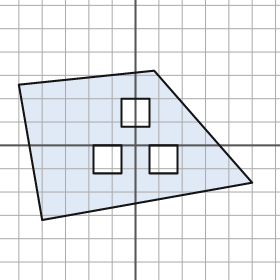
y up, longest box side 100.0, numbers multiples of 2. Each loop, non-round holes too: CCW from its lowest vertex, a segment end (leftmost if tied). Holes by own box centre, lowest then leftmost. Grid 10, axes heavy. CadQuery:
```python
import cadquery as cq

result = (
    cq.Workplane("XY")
    .moveTo(-40.0, -32.0)
    .lineTo(50.0, -16.0)
    .lineTo(8.0, 32.0)
    .lineTo(-50.0, 26.0)
    .close()
    .moveTo(-18.0, -12.0)
    .lineTo(-6.0, -12.0)
    .lineTo(-6.0, 0.0)
    .lineTo(-18.0, 0.0)
    .close()
    .moveTo(6.0, -12.0)
    .lineTo(18.0, -12.0)
    .lineTo(18.0, 0.0)
    .lineTo(6.0, 0.0)
    .close()
    .moveTo(-6.0, 8.0)
    .lineTo(6.0, 8.0)
    .lineTo(6.0, 20.0)
    .lineTo(-6.0, 20.0)
    .close()
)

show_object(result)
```